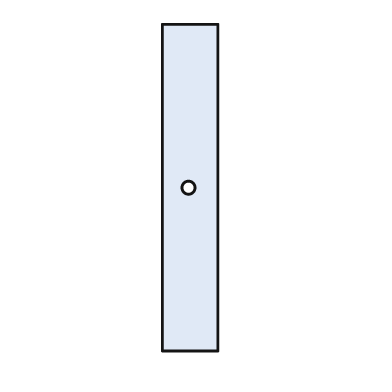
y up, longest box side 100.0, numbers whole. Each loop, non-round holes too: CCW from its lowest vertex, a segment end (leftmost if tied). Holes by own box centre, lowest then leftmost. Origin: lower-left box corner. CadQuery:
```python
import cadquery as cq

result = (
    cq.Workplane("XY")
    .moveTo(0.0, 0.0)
    .lineTo(17.0, 0.0)
    .lineTo(17.0, 100.0)
    .lineTo(0.0, 100.0)
    .close()
    .moveTo(8.0, 50.0)
    .circle(2.0)
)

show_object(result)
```